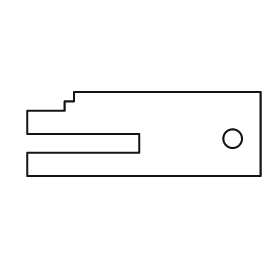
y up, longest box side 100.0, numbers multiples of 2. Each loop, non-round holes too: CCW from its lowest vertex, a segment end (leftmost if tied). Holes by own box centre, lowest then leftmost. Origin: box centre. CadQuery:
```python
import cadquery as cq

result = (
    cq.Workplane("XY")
    .moveTo(-50.0, -18.0)
    .lineTo(50.0, -18.0)
    .lineTo(50.0, 18.0)
    .lineTo(-30.0, 18.0)
    .lineTo(-30.0, 14.0)
    .lineTo(-34.0, 14.0)
    .lineTo(-34.0, 10.0)
    .lineTo(-50.0, 10.0)
    .lineTo(-50.0, 0.0)
    .lineTo(-2.0, 0.0)
    .lineTo(-2.0, -8.0)
    .lineTo(-50.0, -8.0)
    .close()
    .moveTo(38.0, -2.0)
    .circle(4.0)
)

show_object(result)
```